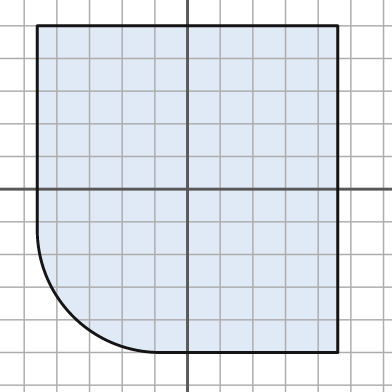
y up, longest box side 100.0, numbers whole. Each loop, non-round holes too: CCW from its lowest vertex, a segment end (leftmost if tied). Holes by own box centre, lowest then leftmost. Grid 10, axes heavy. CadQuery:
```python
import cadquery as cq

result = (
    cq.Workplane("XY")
    .moveTo(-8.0, -50.0)
    .lineTo(46.0, -50.0)
    .lineTo(46.0, 50.0)
    .lineTo(-46.0, 50.0)
    .lineTo(-46.0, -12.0)
    .threePointArc((-35.0, -39.0), (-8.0, -50.0))
    .close()
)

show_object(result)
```